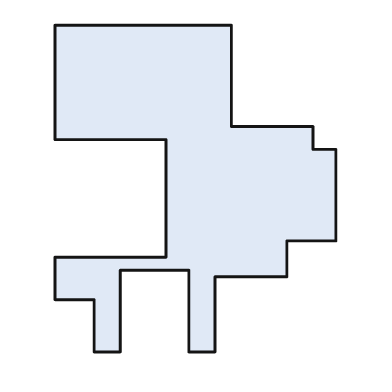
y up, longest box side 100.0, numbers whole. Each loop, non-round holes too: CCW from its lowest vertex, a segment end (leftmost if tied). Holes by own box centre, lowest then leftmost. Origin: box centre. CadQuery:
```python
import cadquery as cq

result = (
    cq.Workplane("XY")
    .moveTo(-31.0, -50.0)
    .lineTo(-23.0, -50.0)
    .lineTo(-23.0, -25.0)
    .lineTo(-2.0, -25.0)
    .lineTo(-2.0, -50.0)
    .lineTo(6.0, -50.0)
    .lineTo(6.0, -27.0)
    .lineTo(28.0, -27.0)
    .lineTo(28.0, -16.0)
    .lineTo(43.0, -16.0)
    .lineTo(43.0, 12.0)
    .lineTo(36.0, 12.0)
    .lineTo(36.0, 19.0)
    .lineTo(11.0, 19.0)
    .lineTo(11.0, 50.0)
    .lineTo(-43.0, 50.0)
    .lineTo(-43.0, 15.0)
    .lineTo(-9.0, 15.0)
    .lineTo(-9.0, -21.0)
    .lineTo(-43.0, -21.0)
    .lineTo(-43.0, -34.0)
    .lineTo(-31.0, -34.0)
    .close()
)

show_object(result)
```